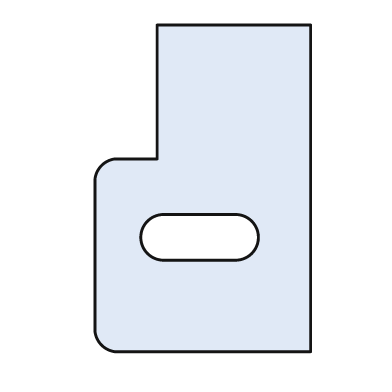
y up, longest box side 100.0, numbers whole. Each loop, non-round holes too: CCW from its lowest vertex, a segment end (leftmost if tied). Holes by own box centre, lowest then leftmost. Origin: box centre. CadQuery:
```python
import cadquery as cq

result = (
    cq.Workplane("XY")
    .moveTo(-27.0, -50.0)
    .lineTo(33.0, -50.0)
    .lineTo(33.0, 50.0)
    .lineTo(-14.0, 50.0)
    .lineTo(-14.0, 9.0)
    .lineTo(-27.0, 9.0)
    .threePointArc((-31.0, 7.0), (-33.0, 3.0))
    .lineTo(-33.0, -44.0)
    .threePointArc((-31.0, -48.0), (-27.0, -50.0))
    .close()
    .moveTo(-12.0, -22.0)
    .lineTo(10.0, -22.0)
    .threePointArc((17.0, -15.0), (10.0, -8.0))
    .lineTo(-12.0, -8.0)
    .threePointArc((-19.0, -15.0), (-12.0, -22.0))
    .close()
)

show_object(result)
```